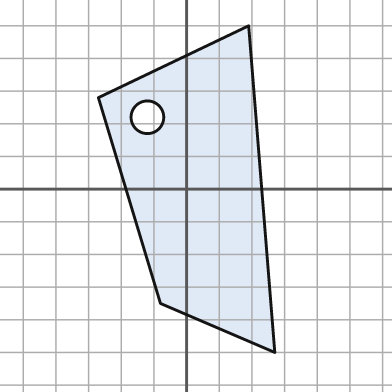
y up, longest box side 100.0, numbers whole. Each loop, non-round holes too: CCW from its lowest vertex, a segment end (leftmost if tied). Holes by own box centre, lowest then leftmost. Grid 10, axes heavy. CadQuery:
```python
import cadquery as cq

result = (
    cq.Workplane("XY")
    .moveTo(27.0, -50.0)
    .lineTo(19.0, 50.0)
    .lineTo(-27.0, 28.0)
    .lineTo(-8.0, -35.0)
    .close()
    .moveTo(-12.0, 22.0)
    .circle(5.0)
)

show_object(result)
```